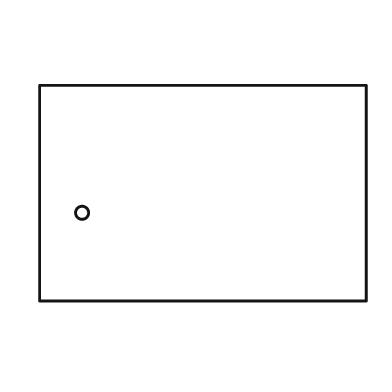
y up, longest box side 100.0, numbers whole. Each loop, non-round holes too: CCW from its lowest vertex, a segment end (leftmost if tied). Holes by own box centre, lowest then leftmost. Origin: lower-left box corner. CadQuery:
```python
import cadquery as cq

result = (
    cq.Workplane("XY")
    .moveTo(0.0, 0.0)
    .lineTo(100.0, 0.0)
    .lineTo(100.0, 66.0)
    .lineTo(0.0, 66.0)
    .close()
    .moveTo(13.0, 27.0)
    .circle(2.0)
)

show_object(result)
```